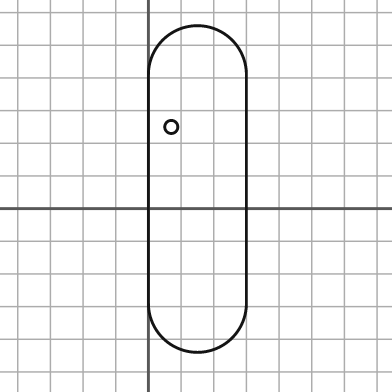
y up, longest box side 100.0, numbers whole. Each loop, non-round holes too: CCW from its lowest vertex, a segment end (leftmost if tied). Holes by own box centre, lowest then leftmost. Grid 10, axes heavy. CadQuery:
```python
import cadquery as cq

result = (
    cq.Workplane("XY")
    .moveTo(0.0, -29.0)
    .threePointArc((15.0, -44.0), (30.0, -29.0))
    .lineTo(30.0, 41.0)
    .threePointArc((15.0, 56.0), (0.0, 41.0))
    .close()
    .moveTo(7.0, 25.0)
    .circle(2.0)
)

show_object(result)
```